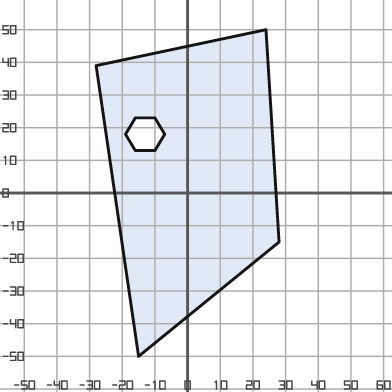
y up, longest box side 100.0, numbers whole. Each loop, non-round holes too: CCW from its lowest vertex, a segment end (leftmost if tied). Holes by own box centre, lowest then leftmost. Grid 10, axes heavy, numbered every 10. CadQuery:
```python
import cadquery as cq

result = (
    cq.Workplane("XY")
    .moveTo(-15.0, -50.0)
    .lineTo(28.0, -15.0)
    .lineTo(24.0, 50.0)
    .lineTo(-28.0, 39.0)
    .close()
    .moveTo(-16.0, 13.0)
    .lineTo(-10.0, 13.0)
    .lineTo(-7.0, 18.0)
    .lineTo(-10.0, 23.0)
    .lineTo(-16.0, 23.0)
    .lineTo(-19.0, 18.0)
    .close()
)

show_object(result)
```